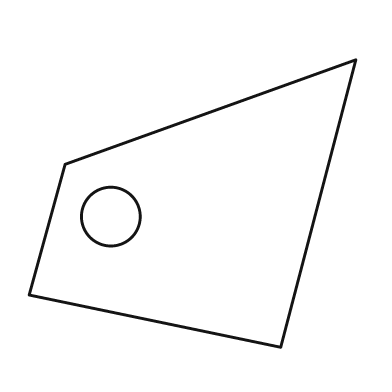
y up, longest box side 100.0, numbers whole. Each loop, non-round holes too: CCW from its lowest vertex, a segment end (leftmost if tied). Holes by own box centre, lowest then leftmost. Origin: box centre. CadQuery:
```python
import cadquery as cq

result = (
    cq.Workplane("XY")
    .moveTo(27.0, -44.0)
    .lineTo(50.0, 44.0)
    .lineTo(-39.0, 12.0)
    .lineTo(-50.0, -28.0)
    .close()
    .moveTo(-25.0, -4.0)
    .circle(9.0)
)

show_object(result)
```